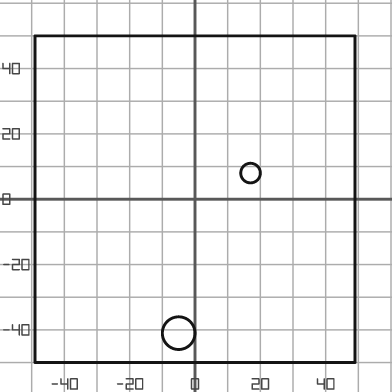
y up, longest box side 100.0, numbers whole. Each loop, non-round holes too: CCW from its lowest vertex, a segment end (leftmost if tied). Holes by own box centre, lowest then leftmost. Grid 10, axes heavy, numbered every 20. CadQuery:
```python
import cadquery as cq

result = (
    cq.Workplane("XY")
    .moveTo(-49.0, -50.0)
    .lineTo(49.0, -50.0)
    .lineTo(49.0, 50.0)
    .lineTo(-49.0, 50.0)
    .close()
    .moveTo(-5.0, -41.0)
    .circle(5.0)
    .moveTo(17.0, 8.0)
    .circle(3.0)
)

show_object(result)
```